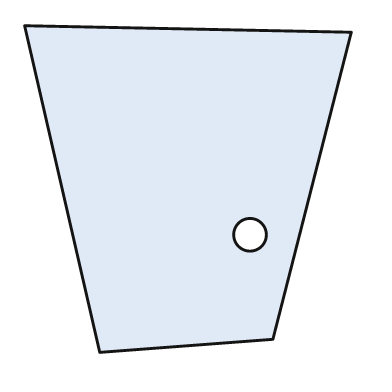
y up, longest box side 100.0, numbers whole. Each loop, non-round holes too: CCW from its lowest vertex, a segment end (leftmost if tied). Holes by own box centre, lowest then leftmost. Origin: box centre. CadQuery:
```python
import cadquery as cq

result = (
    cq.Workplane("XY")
    .moveTo(-27.0, -50.0)
    .lineTo(26.0, -46.0)
    .lineTo(50.0, 48.0)
    .lineTo(-50.0, 50.0)
    .close()
    .moveTo(19.0, -14.0)
    .circle(5.0)
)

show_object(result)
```